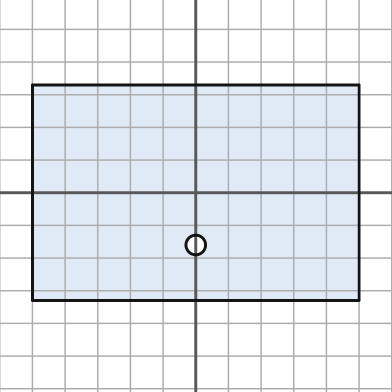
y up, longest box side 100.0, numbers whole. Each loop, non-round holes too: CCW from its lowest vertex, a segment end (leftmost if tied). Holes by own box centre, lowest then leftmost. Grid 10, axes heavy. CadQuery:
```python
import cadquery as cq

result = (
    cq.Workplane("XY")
    .moveTo(-50.0, -33.0)
    .lineTo(50.0, -33.0)
    .lineTo(50.0, 33.0)
    .lineTo(-50.0, 33.0)
    .close()
    .moveTo(0.0, -16.0)
    .circle(3.0)
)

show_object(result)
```